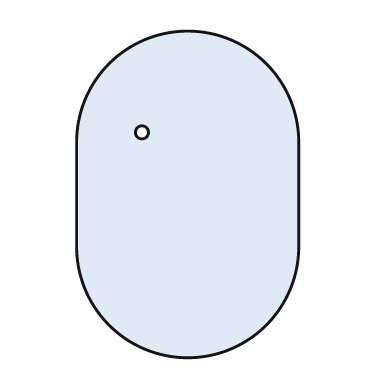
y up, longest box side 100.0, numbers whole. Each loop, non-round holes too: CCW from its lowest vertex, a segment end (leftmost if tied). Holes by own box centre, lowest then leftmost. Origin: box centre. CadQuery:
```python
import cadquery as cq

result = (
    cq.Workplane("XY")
    .moveTo(-34.0, -16.0)
    .threePointArc((0.0, -50.0), (34.0, -16.0))
    .lineTo(34.0, 16.0)
    .threePointArc((0.0, 50.0), (-34.0, 16.0))
    .close()
    .moveTo(-14.0, 19.0)
    .circle(2.0)
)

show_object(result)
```